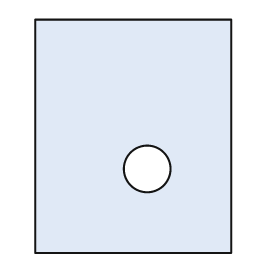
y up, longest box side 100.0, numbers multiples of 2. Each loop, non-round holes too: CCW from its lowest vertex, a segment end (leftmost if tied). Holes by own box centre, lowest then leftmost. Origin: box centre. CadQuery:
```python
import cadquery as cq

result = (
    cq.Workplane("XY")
    .moveTo(-42.0, -50.0)
    .lineTo(42.0, -50.0)
    .lineTo(42.0, 50.0)
    .lineTo(-42.0, 50.0)
    .close()
    .moveTo(6.0, -14.0)
    .circle(10.0)
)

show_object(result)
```